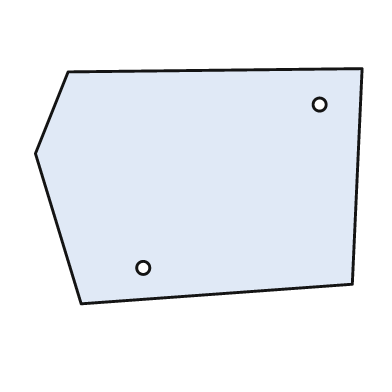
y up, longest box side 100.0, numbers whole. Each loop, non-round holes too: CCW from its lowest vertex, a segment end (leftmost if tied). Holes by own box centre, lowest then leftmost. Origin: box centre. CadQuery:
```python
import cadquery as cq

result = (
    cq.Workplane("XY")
    .moveTo(-36.0, -36.0)
    .lineTo(47.0, -30.0)
    .lineTo(50.0, 36.0)
    .lineTo(-40.0, 35.0)
    .lineTo(-50.0, 10.0)
    .close()
    .moveTo(-17.0, -25.0)
    .circle(2.0)
    .moveTo(37.0, 25.0)
    .circle(2.0)
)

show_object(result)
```